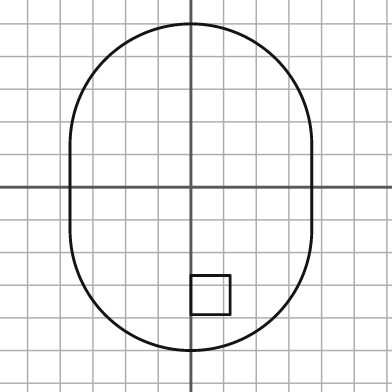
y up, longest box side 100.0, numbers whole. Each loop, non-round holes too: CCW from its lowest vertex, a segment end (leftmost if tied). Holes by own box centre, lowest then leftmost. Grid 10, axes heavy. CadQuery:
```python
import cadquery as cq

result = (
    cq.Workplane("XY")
    .moveTo(-37.0, -13.0)
    .threePointArc((0.0, -50.0), (37.0, -13.0))
    .lineTo(37.0, 13.0)
    .threePointArc((0.0, 50.0), (-37.0, 13.0))
    .close()
    .moveTo(0.0, -39.0)
    .lineTo(12.0, -39.0)
    .lineTo(12.0, -27.0)
    .lineTo(0.0, -27.0)
    .close()
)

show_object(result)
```